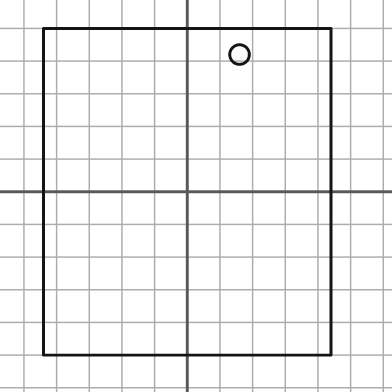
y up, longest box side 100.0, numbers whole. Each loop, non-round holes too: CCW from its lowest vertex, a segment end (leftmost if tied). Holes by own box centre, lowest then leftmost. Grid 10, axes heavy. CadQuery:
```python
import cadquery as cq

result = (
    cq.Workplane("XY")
    .moveTo(-44.0, -50.0)
    .lineTo(44.0, -50.0)
    .lineTo(44.0, 50.0)
    .lineTo(-44.0, 50.0)
    .close()
    .moveTo(16.0, 42.0)
    .circle(3.0)
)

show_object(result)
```